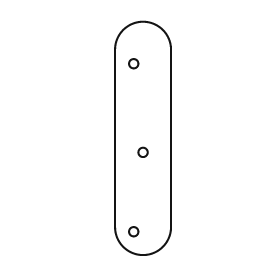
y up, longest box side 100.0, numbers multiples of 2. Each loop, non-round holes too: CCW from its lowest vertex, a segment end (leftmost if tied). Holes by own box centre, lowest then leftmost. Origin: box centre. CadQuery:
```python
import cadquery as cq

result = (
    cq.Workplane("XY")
    .moveTo(-12.0, -38.0)
    .threePointArc((0.0, -50.0), (12.0, -38.0))
    .lineTo(12.0, 38.0)
    .threePointArc((0.0, 50.0), (-12.0, 38.0))
    .close()
    .moveTo(-4.0, -40.0)
    .circle(2.0)
    .moveTo(0.0, -6.0)
    .circle(2.0)
    .moveTo(-4.0, 32.0)
    .circle(2.0)
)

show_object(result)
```